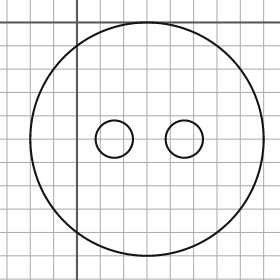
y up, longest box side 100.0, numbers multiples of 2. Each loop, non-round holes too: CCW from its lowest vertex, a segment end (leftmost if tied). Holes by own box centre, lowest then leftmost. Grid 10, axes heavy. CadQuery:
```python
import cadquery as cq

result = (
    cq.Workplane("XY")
    .moveTo(30.0, -50.0)
    .circle(50.0)
    .moveTo(16.0, -50.0)
    .circle(8.0)
    .moveTo(46.0, -50.0)
    .circle(8.0)
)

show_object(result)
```